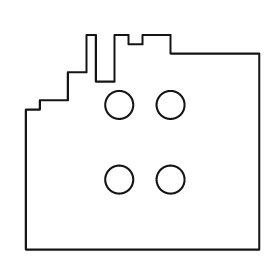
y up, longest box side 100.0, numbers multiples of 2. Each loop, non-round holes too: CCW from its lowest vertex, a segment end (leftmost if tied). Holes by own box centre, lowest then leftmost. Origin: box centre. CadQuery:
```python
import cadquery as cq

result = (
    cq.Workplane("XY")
    .moveTo(-50.0, -46.0)
    .lineTo(50.0, -46.0)
    .lineTo(50.0, 38.0)
    .lineTo(12.0, 38.0)
    .lineTo(12.0, 46.0)
    .lineTo(0.0, 46.0)
    .lineTo(0.0, 42.0)
    .lineTo(-6.0, 42.0)
    .lineTo(-6.0, 46.0)
    .lineTo(-12.0, 46.0)
    .lineTo(-12.0, 26.0)
    .lineTo(-20.0, 26.0)
    .lineTo(-20.0, 46.0)
    .lineTo(-24.0, 46.0)
    .lineTo(-24.0, 30.0)
    .lineTo(-32.0, 30.0)
    .lineTo(-32.0, 18.0)
    .lineTo(-44.0, 18.0)
    .lineTo(-44.0, 14.0)
    .lineTo(-50.0, 14.0)
    .close()
    .moveTo(-10.0, -16.0)
    .circle(6.0)
    .moveTo(12.0, -16.0)
    .circle(6.0)
    .moveTo(-10.0, 16.0)
    .circle(6.0)
    .moveTo(12.0, 16.0)
    .circle(6.0)
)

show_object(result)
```